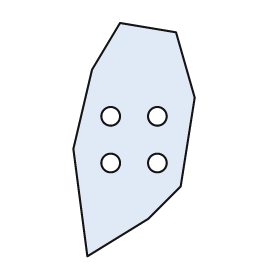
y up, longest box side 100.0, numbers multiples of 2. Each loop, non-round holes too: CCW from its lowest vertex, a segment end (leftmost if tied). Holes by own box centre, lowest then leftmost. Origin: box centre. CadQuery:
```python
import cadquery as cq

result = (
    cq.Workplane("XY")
    .moveTo(-20.0, -50.0)
    .lineTo(6.0, -34.0)
    .lineTo(20.0, -20.0)
    .lineTo(26.0, 18.0)
    .lineTo(18.0, 46.0)
    .lineTo(-6.0, 50.0)
    .lineTo(-18.0, 30.0)
    .lineTo(-26.0, -4.0)
    .close()
    .moveTo(-10.0, -10.0)
    .circle(4.0)
    .moveTo(10.0, -10.0)
    .circle(4.0)
    .moveTo(-10.0, 10.0)
    .circle(4.0)
    .moveTo(10.0, 10.0)
    .circle(4.0)
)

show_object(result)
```